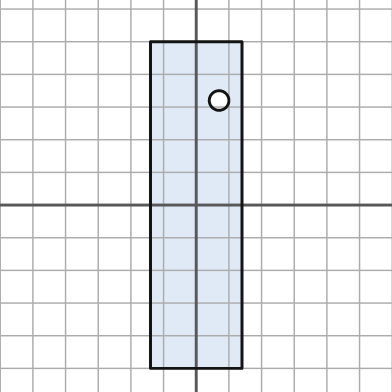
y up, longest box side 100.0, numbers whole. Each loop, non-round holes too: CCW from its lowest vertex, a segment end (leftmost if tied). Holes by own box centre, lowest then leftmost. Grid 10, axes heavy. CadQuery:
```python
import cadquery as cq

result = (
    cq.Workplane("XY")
    .moveTo(-14.0, -50.0)
    .lineTo(14.0, -50.0)
    .lineTo(14.0, 50.0)
    .lineTo(-14.0, 50.0)
    .close()
    .moveTo(7.0, 32.0)
    .circle(3.0)
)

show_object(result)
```